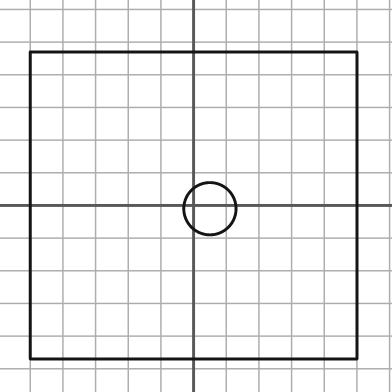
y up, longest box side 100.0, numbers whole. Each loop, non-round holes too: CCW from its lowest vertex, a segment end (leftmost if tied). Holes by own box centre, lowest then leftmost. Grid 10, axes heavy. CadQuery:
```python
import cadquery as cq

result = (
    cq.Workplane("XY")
    .moveTo(-50.0, -47.0)
    .lineTo(50.0, -47.0)
    .lineTo(50.0, 47.0)
    .lineTo(-50.0, 47.0)
    .close()
    .moveTo(5.0, -1.0)
    .circle(8.0)
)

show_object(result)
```